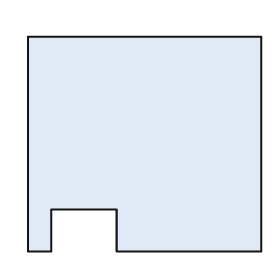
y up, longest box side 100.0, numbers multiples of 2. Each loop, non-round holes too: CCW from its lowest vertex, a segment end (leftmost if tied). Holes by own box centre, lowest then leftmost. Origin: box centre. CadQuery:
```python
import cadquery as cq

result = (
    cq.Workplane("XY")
    .moveTo(-50.0, -46.0)
    .lineTo(-40.0, -46.0)
    .lineTo(-40.0, -28.0)
    .lineTo(-12.0, -28.0)
    .lineTo(-12.0, -46.0)
    .lineTo(50.0, -46.0)
    .lineTo(50.0, 46.0)
    .lineTo(-50.0, 46.0)
    .close()
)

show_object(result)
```